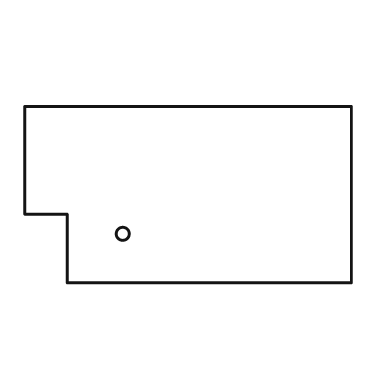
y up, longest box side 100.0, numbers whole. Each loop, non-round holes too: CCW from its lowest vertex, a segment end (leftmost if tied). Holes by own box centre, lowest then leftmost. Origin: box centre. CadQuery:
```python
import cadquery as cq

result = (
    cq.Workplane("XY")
    .moveTo(-37.0, -27.0)
    .lineTo(50.0, -27.0)
    .lineTo(50.0, 27.0)
    .lineTo(-50.0, 27.0)
    .lineTo(-50.0, -6.0)
    .lineTo(-37.0, -6.0)
    .close()
    .moveTo(-20.0, -12.0)
    .circle(2.0)
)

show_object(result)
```